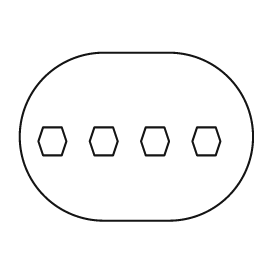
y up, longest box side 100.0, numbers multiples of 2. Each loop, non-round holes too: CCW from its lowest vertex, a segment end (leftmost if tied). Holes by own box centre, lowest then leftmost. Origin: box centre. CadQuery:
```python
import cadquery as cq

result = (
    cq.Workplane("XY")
    .moveTo(-14.0, -36.0)
    .lineTo(14.0, -36.0)
    .threePointArc((50.0, 0.0), (14.0, 36.0))
    .lineTo(-14.0, 36.0)
    .threePointArc((-50.0, 0.0), (-14.0, -36.0))
    .close()
    .moveTo(-40.0, -8.0)
    .lineTo(-32.0, -8.0)
    .lineTo(-30.0, -2.0)
    .lineTo(-32.0, 4.0)
    .lineTo(-40.0, 4.0)
    .lineTo(-42.0, -2.0)
    .close()
    .moveTo(-18.0, -8.0)
    .lineTo(-10.0, -8.0)
    .lineTo(-8.0, -2.0)
    .lineTo(-10.0, 4.0)
    .lineTo(-18.0, 4.0)
    .lineTo(-20.0, -2.0)
    .close()
    .moveTo(4.0, -8.0)
    .lineTo(12.0, -8.0)
    .lineTo(14.0, -2.0)
    .lineTo(12.0, 4.0)
    .lineTo(4.0, 4.0)
    .lineTo(2.0, -2.0)
    .close()
    .moveTo(26.0, -8.0)
    .lineTo(34.0, -8.0)
    .lineTo(36.0, -2.0)
    .lineTo(34.0, 4.0)
    .lineTo(26.0, 4.0)
    .lineTo(24.0, -2.0)
    .close()
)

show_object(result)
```